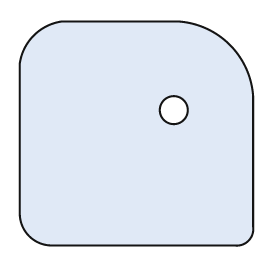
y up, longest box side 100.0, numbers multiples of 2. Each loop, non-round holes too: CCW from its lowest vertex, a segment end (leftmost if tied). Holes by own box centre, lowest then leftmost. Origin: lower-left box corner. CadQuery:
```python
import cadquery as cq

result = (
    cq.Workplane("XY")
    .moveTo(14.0, 0.0)
    .lineTo(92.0, 0.0)
    .threePointArc((98.0, 2.0), (100.0, 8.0))
    .lineTo(100.0, 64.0)
    .threePointArc((90.0, 86.0), (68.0, 96.0))
    .lineTo(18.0, 96.0)
    .threePointArc((6.0, 90.0), (0.0, 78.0))
    .lineTo(0.0, 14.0)
    .threePointArc((4.0, 4.0), (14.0, 0.0))
    .close()
    .moveTo(66.0, 58.0)
    .circle(6.0)
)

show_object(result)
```